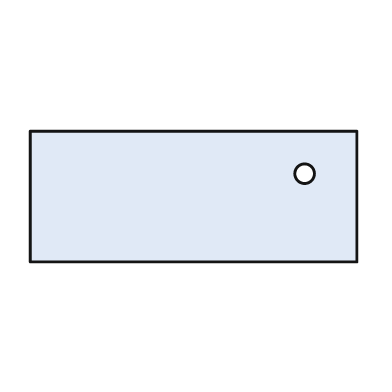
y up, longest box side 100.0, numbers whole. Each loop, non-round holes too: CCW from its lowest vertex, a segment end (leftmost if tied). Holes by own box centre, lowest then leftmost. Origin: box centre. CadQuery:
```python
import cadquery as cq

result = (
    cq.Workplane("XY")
    .moveTo(-50.0, -20.0)
    .lineTo(50.0, -20.0)
    .lineTo(50.0, 20.0)
    .lineTo(-50.0, 20.0)
    .close()
    .moveTo(34.0, 7.0)
    .circle(3.0)
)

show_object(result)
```